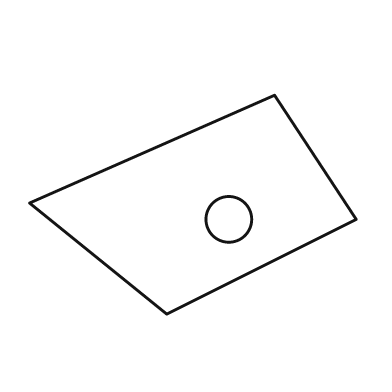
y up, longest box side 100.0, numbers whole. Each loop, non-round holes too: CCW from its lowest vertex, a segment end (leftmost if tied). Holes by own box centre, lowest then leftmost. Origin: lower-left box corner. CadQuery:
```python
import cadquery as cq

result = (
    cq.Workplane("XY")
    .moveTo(42.0, 0.0)
    .lineTo(100.0, 29.0)
    .lineTo(75.0, 67.0)
    .lineTo(0.0, 34.0)
    .close()
    .moveTo(61.0, 29.0)
    .circle(7.0)
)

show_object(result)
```